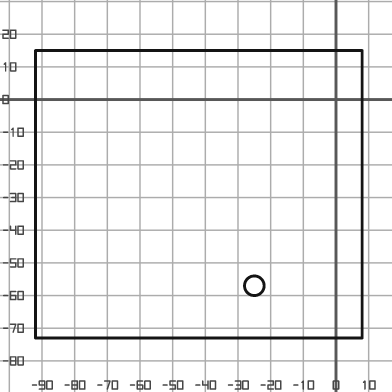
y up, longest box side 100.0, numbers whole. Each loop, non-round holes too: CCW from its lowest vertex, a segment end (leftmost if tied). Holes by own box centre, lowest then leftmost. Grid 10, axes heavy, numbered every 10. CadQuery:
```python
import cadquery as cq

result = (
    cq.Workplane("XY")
    .moveTo(-92.0, -73.0)
    .lineTo(8.0, -73.0)
    .lineTo(8.0, 15.0)
    .lineTo(-92.0, 15.0)
    .close()
    .moveTo(-25.0, -57.0)
    .circle(3.0)
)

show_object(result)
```